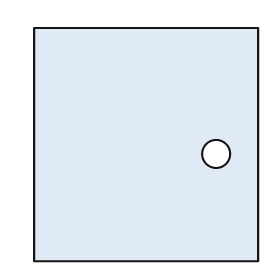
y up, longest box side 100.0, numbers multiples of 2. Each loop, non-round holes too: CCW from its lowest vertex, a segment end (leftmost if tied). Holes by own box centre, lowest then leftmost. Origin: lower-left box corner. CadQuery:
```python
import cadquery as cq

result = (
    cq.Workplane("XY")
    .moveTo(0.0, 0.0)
    .lineTo(96.0, 0.0)
    .lineTo(96.0, 100.0)
    .lineTo(0.0, 100.0)
    .close()
    .moveTo(78.0, 46.0)
    .circle(6.0)
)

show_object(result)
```